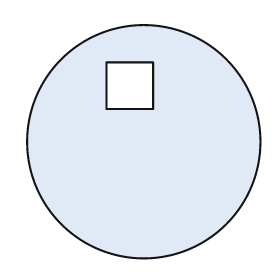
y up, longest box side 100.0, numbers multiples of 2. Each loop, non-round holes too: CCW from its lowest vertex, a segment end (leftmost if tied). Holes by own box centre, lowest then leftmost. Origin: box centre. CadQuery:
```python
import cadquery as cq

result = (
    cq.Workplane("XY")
    .moveTo(0.0, 0.0)
    .circle(50.0)
    .moveTo(-16.0, 14.0)
    .lineTo(4.0, 14.0)
    .lineTo(4.0, 34.0)
    .lineTo(-16.0, 34.0)
    .close()
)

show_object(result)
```